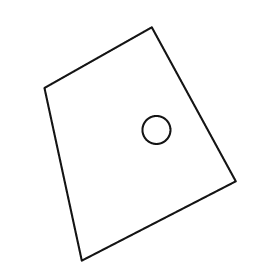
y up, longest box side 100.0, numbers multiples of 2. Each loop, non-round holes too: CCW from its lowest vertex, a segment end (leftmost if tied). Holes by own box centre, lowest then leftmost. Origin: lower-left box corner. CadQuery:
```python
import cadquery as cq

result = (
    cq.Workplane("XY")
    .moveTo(16.0, 0.0)
    .lineTo(82.0, 34.0)
    .lineTo(46.0, 100.0)
    .lineTo(0.0, 74.0)
    .close()
    .moveTo(48.0, 56.0)
    .circle(6.0)
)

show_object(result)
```